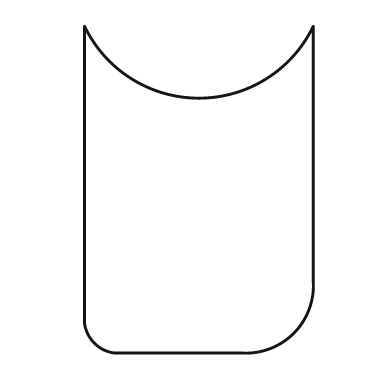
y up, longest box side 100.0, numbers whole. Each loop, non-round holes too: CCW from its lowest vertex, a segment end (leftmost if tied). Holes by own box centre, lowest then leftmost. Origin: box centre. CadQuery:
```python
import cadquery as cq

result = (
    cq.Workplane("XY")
    .moveTo(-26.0, -50.0)
    .lineTo(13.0, -50.0)
    .threePointArc((29.0, -44.0), (35.0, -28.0))
    .lineTo(35.0, 50.0)
    .threePointArc((0.0, 28.0), (-35.0, 50.0))
    .lineTo(-35.0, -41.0)
    .threePointArc((-32.0, -47.0), (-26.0, -50.0))
    .close()
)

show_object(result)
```